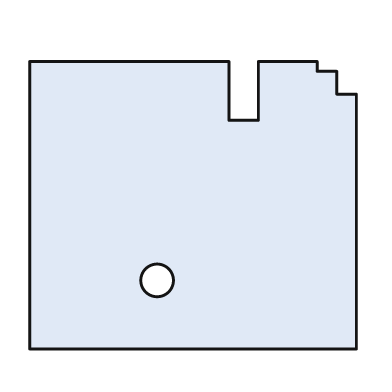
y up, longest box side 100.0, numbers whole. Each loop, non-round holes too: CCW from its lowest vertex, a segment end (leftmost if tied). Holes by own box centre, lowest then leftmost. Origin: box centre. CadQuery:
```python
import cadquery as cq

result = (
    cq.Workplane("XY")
    .moveTo(-50.0, -44.0)
    .lineTo(50.0, -44.0)
    .lineTo(50.0, 34.0)
    .lineTo(44.0, 34.0)
    .lineTo(44.0, 41.0)
    .lineTo(38.0, 41.0)
    .lineTo(38.0, 44.0)
    .lineTo(20.0, 44.0)
    .lineTo(20.0, 26.0)
    .lineTo(11.0, 26.0)
    .lineTo(11.0, 44.0)
    .lineTo(-50.0, 44.0)
    .close()
    .moveTo(-11.0, -23.0)
    .circle(5.0)
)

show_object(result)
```